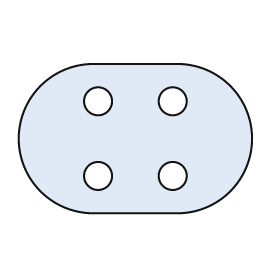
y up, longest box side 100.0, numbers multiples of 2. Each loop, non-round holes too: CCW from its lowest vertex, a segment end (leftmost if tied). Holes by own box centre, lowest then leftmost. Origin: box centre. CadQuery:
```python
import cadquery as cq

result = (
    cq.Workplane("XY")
    .moveTo(-18.0, -32.0)
    .lineTo(18.0, -32.0)
    .threePointArc((50.0, 0.0), (18.0, 32.0))
    .lineTo(-18.0, 32.0)
    .threePointArc((-50.0, 0.0), (-18.0, -32.0))
    .close()
    .moveTo(-16.0, -16.0)
    .circle(6.0)
    .moveTo(16.0, -16.0)
    .circle(6.0)
    .moveTo(-16.0, 16.0)
    .circle(6.0)
    .moveTo(16.0, 16.0)
    .circle(6.0)
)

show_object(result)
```